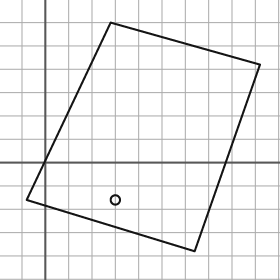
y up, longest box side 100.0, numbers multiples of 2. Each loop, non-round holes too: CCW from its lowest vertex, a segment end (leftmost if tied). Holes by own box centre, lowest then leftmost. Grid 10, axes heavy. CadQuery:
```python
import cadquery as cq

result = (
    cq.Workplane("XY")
    .moveTo(64.0, -38.0)
    .lineTo(92.0, 42.0)
    .lineTo(28.0, 60.0)
    .lineTo(-8.0, -16.0)
    .close()
    .moveTo(30.0, -16.0)
    .circle(2.0)
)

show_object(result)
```